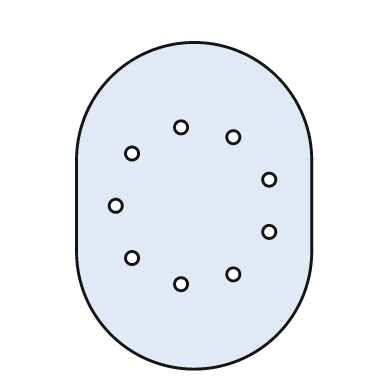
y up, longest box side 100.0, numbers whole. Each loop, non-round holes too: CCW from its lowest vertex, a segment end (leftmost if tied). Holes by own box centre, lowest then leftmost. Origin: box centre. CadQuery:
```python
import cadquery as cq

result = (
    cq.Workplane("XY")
    .moveTo(-36.0, -14.0)
    .threePointArc((0.0, -50.0), (36.0, -14.0))
    .lineTo(36.0, 14.0)
    .threePointArc((0.0, 50.0), (-36.0, 14.0))
    .close()
    .moveTo(-4.0, -24.0)
    .circle(2.0)
    .moveTo(12.0, -21.0)
    .circle(2.0)
    .moveTo(-19.0, -16.0)
    .circle(2.0)
    .moveTo(23.0, -8.0)
    .circle(2.0)
    .moveTo(-24.0, 0.0)
    .circle(2.0)
    .moveTo(23.0, 8.0)
    .circle(2.0)
    .moveTo(-19.0, 16.0)
    .circle(2.0)
    .moveTo(12.0, 21.0)
    .circle(2.0)
    .moveTo(-4.0, 24.0)
    .circle(2.0)
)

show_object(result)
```